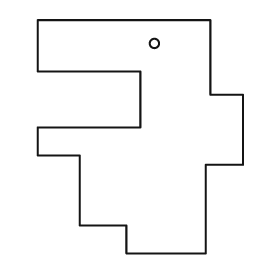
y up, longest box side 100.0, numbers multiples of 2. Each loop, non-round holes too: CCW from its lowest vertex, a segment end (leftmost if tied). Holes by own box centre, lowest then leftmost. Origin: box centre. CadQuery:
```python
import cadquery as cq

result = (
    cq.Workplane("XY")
    .moveTo(-6.0, -50.0)
    .lineTo(28.0, -50.0)
    .lineTo(28.0, -12.0)
    .lineTo(44.0, -12.0)
    .lineTo(44.0, 18.0)
    .lineTo(30.0, 18.0)
    .lineTo(30.0, 50.0)
    .lineTo(-44.0, 50.0)
    .lineTo(-44.0, 28.0)
    .lineTo(0.0, 28.0)
    .lineTo(0.0, 4.0)
    .lineTo(-44.0, 4.0)
    .lineTo(-44.0, -8.0)
    .lineTo(-26.0, -8.0)
    .lineTo(-26.0, -38.0)
    .lineTo(-6.0, -38.0)
    .close()
    .moveTo(6.0, 40.0)
    .circle(2.0)
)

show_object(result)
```